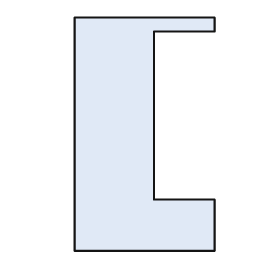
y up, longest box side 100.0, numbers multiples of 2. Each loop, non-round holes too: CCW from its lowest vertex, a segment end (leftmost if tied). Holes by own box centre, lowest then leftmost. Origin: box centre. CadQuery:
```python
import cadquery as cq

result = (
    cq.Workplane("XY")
    .moveTo(-30.0, -50.0)
    .lineTo(30.0, -50.0)
    .lineTo(30.0, -28.0)
    .lineTo(4.0, -28.0)
    .lineTo(4.0, 44.0)
    .lineTo(30.0, 44.0)
    .lineTo(30.0, 50.0)
    .lineTo(-30.0, 50.0)
    .close()
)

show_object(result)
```